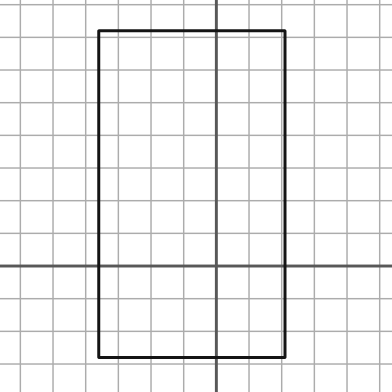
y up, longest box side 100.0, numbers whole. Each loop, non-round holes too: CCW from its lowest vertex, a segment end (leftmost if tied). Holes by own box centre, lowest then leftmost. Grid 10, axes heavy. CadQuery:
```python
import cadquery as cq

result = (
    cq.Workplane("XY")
    .moveTo(-36.0, -28.0)
    .lineTo(21.0, -28.0)
    .lineTo(21.0, 72.0)
    .lineTo(-36.0, 72.0)
    .close()
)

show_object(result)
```